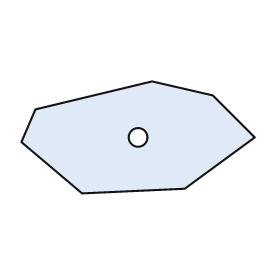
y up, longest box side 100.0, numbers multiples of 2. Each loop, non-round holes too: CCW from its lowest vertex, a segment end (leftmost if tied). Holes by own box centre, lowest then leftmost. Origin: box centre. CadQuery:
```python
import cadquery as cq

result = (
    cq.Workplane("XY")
    .moveTo(-24.0, -24.0)
    .lineTo(20.0, -22.0)
    .lineTo(50.0, 0.0)
    .lineTo(32.0, 18.0)
    .lineTo(6.0, 24.0)
    .lineTo(-44.0, 12.0)
    .lineTo(-50.0, -2.0)
    .close()
    .moveTo(0.0, 0.0)
    .circle(4.0)
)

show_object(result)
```